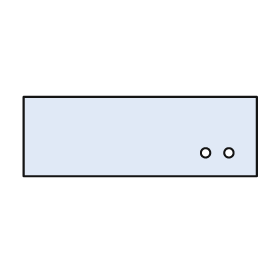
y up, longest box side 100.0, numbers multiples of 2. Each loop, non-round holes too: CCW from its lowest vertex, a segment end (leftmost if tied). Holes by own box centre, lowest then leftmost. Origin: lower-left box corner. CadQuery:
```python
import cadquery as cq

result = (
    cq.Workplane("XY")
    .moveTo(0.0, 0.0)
    .lineTo(100.0, 0.0)
    .lineTo(100.0, 34.0)
    .lineTo(0.0, 34.0)
    .close()
    .moveTo(78.0, 10.0)
    .circle(2.0)
    .moveTo(88.0, 10.0)
    .circle(2.0)
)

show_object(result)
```